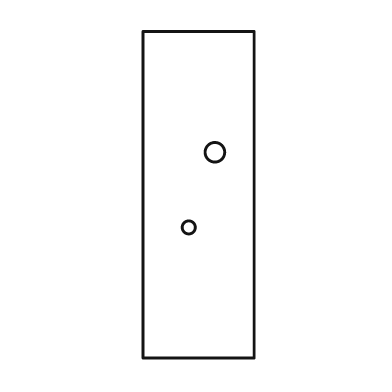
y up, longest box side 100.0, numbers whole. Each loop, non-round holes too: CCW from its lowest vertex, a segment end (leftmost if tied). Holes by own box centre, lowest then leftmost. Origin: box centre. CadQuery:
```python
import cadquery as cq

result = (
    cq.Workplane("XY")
    .moveTo(-17.0, -50.0)
    .lineTo(17.0, -50.0)
    .lineTo(17.0, 50.0)
    .lineTo(-17.0, 50.0)
    .close()
    .moveTo(-3.0, -10.0)
    .circle(2.0)
    .moveTo(5.0, 13.0)
    .circle(3.0)
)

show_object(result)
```